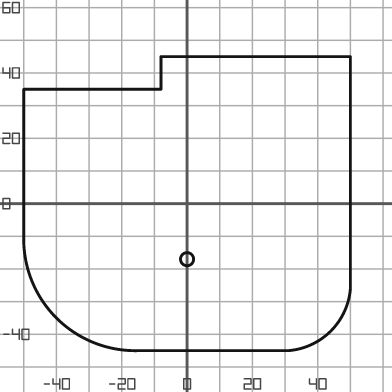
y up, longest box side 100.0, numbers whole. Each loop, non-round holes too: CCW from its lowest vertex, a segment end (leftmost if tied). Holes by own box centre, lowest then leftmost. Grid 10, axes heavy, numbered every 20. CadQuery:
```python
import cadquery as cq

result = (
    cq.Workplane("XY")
    .moveTo(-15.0, -45.0)
    .lineTo(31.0, -45.0)
    .threePointArc((44.0, -39.0), (50.0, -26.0))
    .lineTo(50.0, 45.0)
    .lineTo(-8.0, 45.0)
    .lineTo(-8.0, 35.0)
    .lineTo(-50.0, 35.0)
    .lineTo(-50.0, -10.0)
    .threePointArc((-40.0, -35.0), (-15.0, -45.0))
    .close()
    .moveTo(0.0, -17.0)
    .circle(2.0)
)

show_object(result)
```